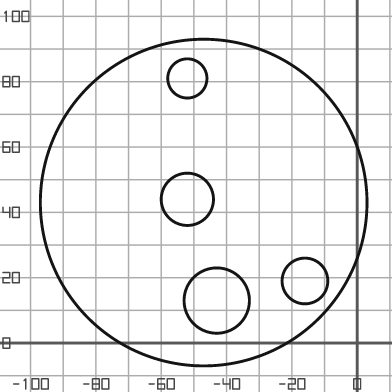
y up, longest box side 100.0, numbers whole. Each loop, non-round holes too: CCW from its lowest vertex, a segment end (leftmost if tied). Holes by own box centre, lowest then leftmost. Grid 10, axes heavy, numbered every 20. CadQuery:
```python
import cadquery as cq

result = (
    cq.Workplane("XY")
    .moveTo(-47.0, 43.0)
    .circle(50.0)
    .moveTo(-43.0, 13.0)
    .circle(10.0)
    .moveTo(-16.0, 19.0)
    .circle(7.0)
    .moveTo(-52.0, 44.0)
    .circle(8.0)
    .moveTo(-52.0, 81.0)
    .circle(6.0)
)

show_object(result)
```